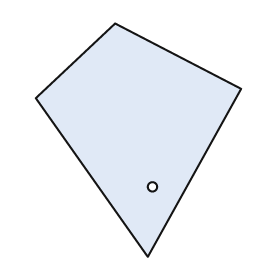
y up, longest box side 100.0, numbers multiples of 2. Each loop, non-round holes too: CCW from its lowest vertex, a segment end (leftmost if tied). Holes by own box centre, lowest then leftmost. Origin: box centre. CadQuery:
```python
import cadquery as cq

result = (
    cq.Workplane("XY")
    .moveTo(4.0, -50.0)
    .lineTo(44.0, 22.0)
    .lineTo(-10.0, 50.0)
    .lineTo(-44.0, 18.0)
    .close()
    .moveTo(6.0, -20.0)
    .circle(2.0)
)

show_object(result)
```